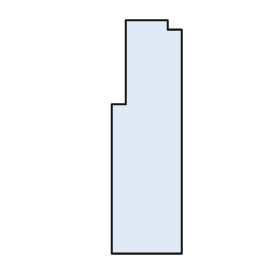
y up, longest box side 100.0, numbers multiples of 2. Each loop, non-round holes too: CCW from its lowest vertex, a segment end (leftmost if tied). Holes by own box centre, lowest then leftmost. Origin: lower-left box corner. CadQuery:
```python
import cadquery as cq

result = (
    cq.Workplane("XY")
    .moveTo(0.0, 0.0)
    .lineTo(30.0, 0.0)
    .lineTo(30.0, 96.0)
    .lineTo(24.0, 96.0)
    .lineTo(24.0, 100.0)
    .lineTo(6.0, 100.0)
    .lineTo(6.0, 64.0)
    .lineTo(0.0, 64.0)
    .close()
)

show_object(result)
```